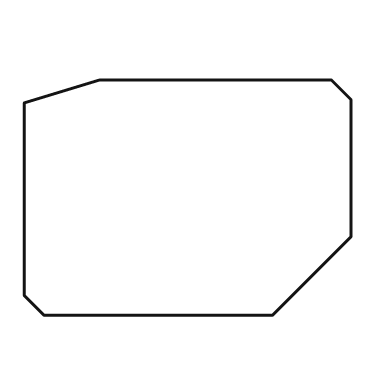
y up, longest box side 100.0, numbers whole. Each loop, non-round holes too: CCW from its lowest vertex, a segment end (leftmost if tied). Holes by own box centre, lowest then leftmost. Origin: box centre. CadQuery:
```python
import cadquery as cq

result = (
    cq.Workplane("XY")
    .moveTo(-44.0, -36.0)
    .lineTo(26.0, -36.0)
    .lineTo(50.0, -12.0)
    .lineTo(50.0, 30.0)
    .lineTo(44.0, 36.0)
    .lineTo(-27.0, 36.0)
    .lineTo(-50.0, 29.0)
    .lineTo(-50.0, -30.0)
    .close()
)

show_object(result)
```